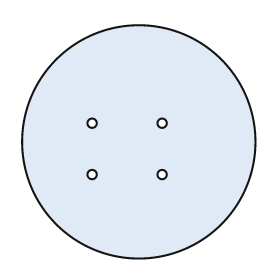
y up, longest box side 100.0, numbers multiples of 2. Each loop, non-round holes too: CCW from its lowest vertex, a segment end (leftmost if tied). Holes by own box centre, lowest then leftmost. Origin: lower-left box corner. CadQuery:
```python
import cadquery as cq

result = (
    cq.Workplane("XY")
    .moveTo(50.0, 50.0)
    .circle(50.0)
    .moveTo(30.0, 36.0)
    .circle(2.0)
    .moveTo(60.0, 36.0)
    .circle(2.0)
    .moveTo(30.0, 58.0)
    .circle(2.0)
    .moveTo(60.0, 58.0)
    .circle(2.0)
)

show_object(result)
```